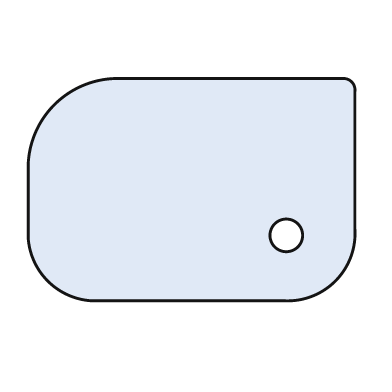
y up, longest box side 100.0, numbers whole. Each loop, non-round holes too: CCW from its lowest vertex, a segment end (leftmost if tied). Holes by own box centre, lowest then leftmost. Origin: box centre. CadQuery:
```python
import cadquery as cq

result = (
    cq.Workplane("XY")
    .moveTo(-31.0, -34.0)
    .lineTo(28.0, -34.0)
    .threePointArc((44.0, -28.0), (50.0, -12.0))
    .lineTo(50.0, 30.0)
    .threePointArc((49.0, 33.0), (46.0, 34.0))
    .lineTo(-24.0, 34.0)
    .threePointArc((-42.0, 26.0), (-50.0, 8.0))
    .lineTo(-50.0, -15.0)
    .threePointArc((-44.0, -28.0), (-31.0, -34.0))
    .close()
    .moveTo(29.0, -14.0)
    .circle(5.0)
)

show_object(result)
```